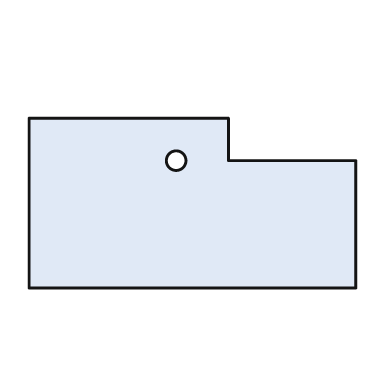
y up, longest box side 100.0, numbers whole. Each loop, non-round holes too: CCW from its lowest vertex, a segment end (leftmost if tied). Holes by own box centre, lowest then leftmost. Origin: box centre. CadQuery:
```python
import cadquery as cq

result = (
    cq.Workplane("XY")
    .moveTo(-50.0, -26.0)
    .lineTo(50.0, -26.0)
    .lineTo(50.0, 13.0)
    .lineTo(11.0, 13.0)
    .lineTo(11.0, 26.0)
    .lineTo(-50.0, 26.0)
    .close()
    .moveTo(-5.0, 13.0)
    .circle(3.0)
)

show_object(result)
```